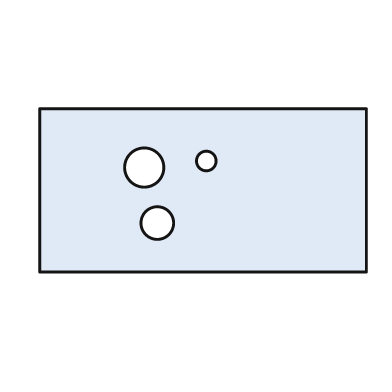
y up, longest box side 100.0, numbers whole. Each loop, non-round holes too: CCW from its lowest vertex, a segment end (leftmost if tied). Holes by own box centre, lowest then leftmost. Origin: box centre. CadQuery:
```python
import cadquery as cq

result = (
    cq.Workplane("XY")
    .moveTo(-50.0, -25.0)
    .lineTo(50.0, -25.0)
    .lineTo(50.0, 25.0)
    .lineTo(-50.0, 25.0)
    .close()
    .moveTo(-14.0, -10.0)
    .circle(5.0)
    .moveTo(-18.0, 7.0)
    .circle(6.0)
    .moveTo(1.0, 9.0)
    .circle(3.0)
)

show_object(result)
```